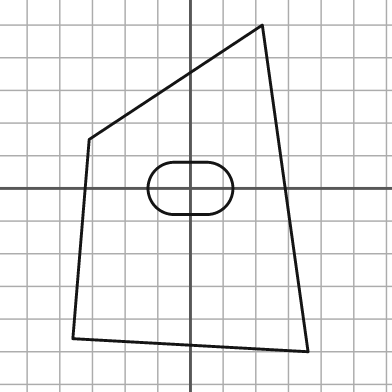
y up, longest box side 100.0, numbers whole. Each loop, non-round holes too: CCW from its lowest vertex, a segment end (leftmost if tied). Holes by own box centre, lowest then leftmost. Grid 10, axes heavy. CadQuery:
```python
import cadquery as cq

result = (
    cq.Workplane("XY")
    .moveTo(36.0, -50.0)
    .lineTo(22.0, 50.0)
    .lineTo(-31.0, 15.0)
    .lineTo(-36.0, -46.0)
    .close()
    .moveTo(-5.0, -8.0)
    .lineTo(5.0, -8.0)
    .threePointArc((13.0, 0.0), (5.0, 8.0))
    .lineTo(-5.0, 8.0)
    .threePointArc((-13.0, 0.0), (-5.0, -8.0))
    .close()
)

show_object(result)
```